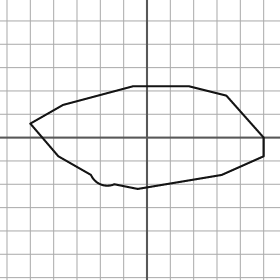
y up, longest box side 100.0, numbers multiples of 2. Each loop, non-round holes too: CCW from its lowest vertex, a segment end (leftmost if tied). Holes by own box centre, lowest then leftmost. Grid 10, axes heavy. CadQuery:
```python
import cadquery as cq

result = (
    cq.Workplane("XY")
    .moveTo(-4.0, -22.0)
    .lineTo(32.0, -16.0)
    .lineTo(50.0, -8.0)
    .lineTo(50.0, 0.0)
    .lineTo(34.0, 18.0)
    .lineTo(18.0, 22.0)
    .lineTo(-6.0, 22.0)
    .lineTo(-36.0, 14.0)
    .lineTo(-50.0, 6.0)
    .lineTo(-38.0, -8.0)
    .lineTo(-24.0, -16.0)
    .threePointArc((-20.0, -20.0), (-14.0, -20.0))
    .close()
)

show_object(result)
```